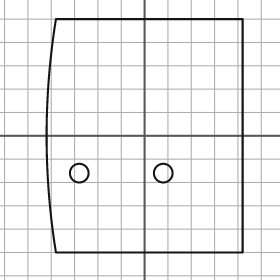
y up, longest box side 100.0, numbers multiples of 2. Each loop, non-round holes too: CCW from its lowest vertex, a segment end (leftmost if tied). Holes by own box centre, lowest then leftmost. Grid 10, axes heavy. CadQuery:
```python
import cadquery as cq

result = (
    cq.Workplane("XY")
    .moveTo(-38.0, -50.0)
    .lineTo(42.0, -50.0)
    .lineTo(42.0, 50.0)
    .lineTo(-38.0, 50.0)
    .threePointArc((-42.0, 0.0), (-38.0, -50.0))
    .close()
    .moveTo(-28.0, -16.0)
    .circle(4.0)
    .moveTo(8.0, -16.0)
    .circle(4.0)
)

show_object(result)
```